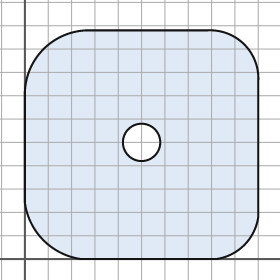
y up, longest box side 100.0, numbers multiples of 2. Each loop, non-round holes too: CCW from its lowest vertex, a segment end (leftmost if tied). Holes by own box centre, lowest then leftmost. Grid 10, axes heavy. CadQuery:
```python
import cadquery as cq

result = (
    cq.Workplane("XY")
    .moveTo(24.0, 0.0)
    .lineTo(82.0, 0.0)
    .threePointArc((94.0, 6.0), (100.0, 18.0))
    .lineTo(100.0, 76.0)
    .threePointArc((94.0, 92.0), (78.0, 98.0))
    .lineTo(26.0, 98.0)
    .threePointArc((8.0, 90.0), (0.0, 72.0))
    .lineTo(0.0, 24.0)
    .threePointArc((8.0, 8.0), (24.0, 0.0))
    .close()
    .moveTo(50.0, 50.0)
    .circle(8.0)
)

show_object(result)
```